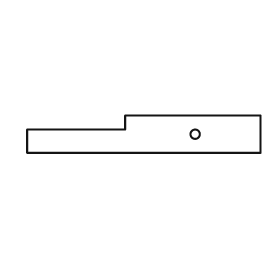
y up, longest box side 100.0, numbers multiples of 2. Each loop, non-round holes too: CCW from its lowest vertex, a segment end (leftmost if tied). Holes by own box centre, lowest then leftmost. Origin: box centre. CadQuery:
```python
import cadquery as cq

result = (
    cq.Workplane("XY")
    .moveTo(-50.0, -8.0)
    .lineTo(50.0, -8.0)
    .lineTo(50.0, 8.0)
    .lineTo(-8.0, 8.0)
    .lineTo(-8.0, 2.0)
    .lineTo(-50.0, 2.0)
    .close()
    .moveTo(22.0, 0.0)
    .circle(2.0)
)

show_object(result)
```